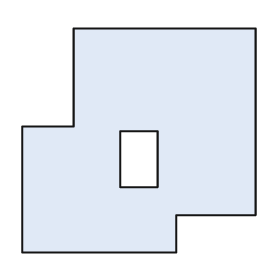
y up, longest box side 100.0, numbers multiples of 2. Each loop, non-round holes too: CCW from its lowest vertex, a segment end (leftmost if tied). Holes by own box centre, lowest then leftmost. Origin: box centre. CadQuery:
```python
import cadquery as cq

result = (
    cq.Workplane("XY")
    .moveTo(-50.0, -48.0)
    .lineTo(16.0, -48.0)
    .lineTo(16.0, -32.0)
    .lineTo(50.0, -32.0)
    .lineTo(50.0, 48.0)
    .lineTo(-28.0, 48.0)
    .lineTo(-28.0, 6.0)
    .lineTo(-50.0, 6.0)
    .close()
    .moveTo(-8.0, -20.0)
    .lineTo(8.0, -20.0)
    .lineTo(8.0, 4.0)
    .lineTo(-8.0, 4.0)
    .close()
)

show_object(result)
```